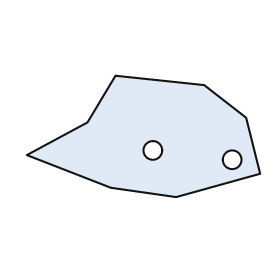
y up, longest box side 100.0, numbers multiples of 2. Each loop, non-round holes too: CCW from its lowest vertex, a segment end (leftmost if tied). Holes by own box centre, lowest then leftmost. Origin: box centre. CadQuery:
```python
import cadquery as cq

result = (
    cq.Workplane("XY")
    .moveTo(14.0, -26.0)
    .lineTo(50.0, -16.0)
    .lineTo(44.0, 8.0)
    .lineTo(26.0, 22.0)
    .lineTo(-12.0, 26.0)
    .lineTo(-24.0, 6.0)
    .lineTo(-50.0, -8.0)
    .lineTo(-14.0, -22.0)
    .close()
    .moveTo(38.0, -10.0)
    .circle(4.0)
    .moveTo(4.0, -6.0)
    .circle(4.0)
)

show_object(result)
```